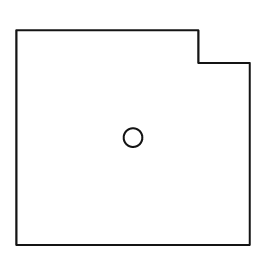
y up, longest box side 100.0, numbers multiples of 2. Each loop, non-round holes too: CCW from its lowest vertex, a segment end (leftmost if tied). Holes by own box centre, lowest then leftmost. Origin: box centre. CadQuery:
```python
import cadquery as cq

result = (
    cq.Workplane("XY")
    .moveTo(-50.0, -46.0)
    .lineTo(50.0, -46.0)
    .lineTo(50.0, 32.0)
    .lineTo(28.0, 32.0)
    .lineTo(28.0, 46.0)
    .lineTo(-50.0, 46.0)
    .close()
    .moveTo(0.0, 0.0)
    .circle(4.0)
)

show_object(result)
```